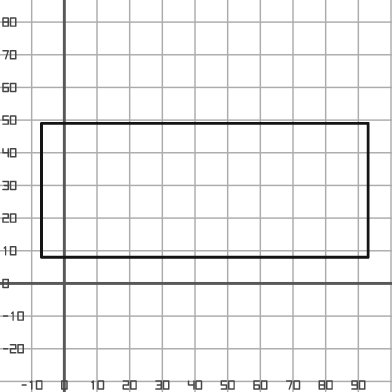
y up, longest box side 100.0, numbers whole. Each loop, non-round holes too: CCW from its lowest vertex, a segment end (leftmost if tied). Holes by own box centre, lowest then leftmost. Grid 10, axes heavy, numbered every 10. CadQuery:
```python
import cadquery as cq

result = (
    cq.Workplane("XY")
    .moveTo(-7.0, 8.0)
    .lineTo(93.0, 8.0)
    .lineTo(93.0, 49.0)
    .lineTo(-7.0, 49.0)
    .close()
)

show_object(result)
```